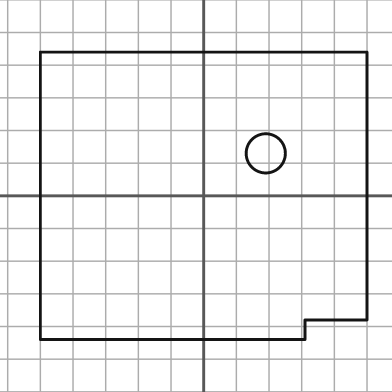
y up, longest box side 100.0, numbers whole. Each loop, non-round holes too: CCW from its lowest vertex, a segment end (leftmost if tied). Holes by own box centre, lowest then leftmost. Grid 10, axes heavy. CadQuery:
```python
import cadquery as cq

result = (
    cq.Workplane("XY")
    .moveTo(-50.0, -44.0)
    .lineTo(31.0, -44.0)
    .lineTo(31.0, -38.0)
    .lineTo(50.0, -38.0)
    .lineTo(50.0, 44.0)
    .lineTo(-50.0, 44.0)
    .close()
    .moveTo(19.0, 13.0)
    .circle(6.0)
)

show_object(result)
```